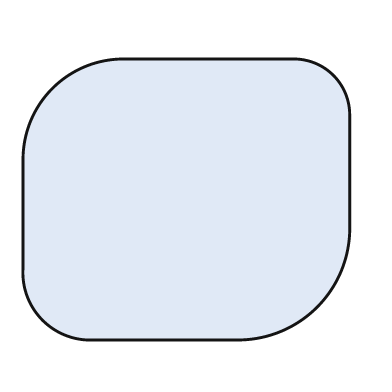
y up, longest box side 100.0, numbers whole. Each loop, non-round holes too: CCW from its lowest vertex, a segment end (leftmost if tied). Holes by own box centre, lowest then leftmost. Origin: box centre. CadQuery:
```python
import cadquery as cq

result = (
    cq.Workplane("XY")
    .moveTo(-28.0, -43.0)
    .lineTo(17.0, -43.0)
    .threePointArc((40.0, -33.0), (50.0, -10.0))
    .lineTo(50.0, 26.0)
    .threePointArc((45.0, 38.0), (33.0, 43.0))
    .lineTo(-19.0, 43.0)
    .threePointArc((-41.0, 34.0), (-50.0, 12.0))
    .lineTo(-50.0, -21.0)
    .threePointArc((-44.0, -37.0), (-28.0, -43.0))
    .close()
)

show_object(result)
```